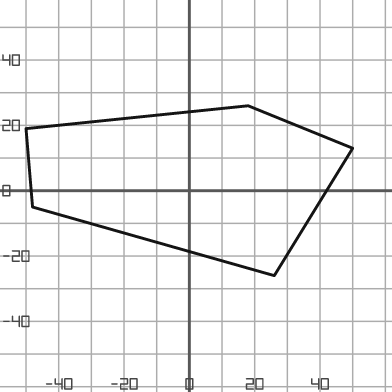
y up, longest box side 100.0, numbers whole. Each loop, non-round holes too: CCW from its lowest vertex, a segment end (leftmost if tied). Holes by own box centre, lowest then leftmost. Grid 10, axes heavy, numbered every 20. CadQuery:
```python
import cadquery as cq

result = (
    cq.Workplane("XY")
    .moveTo(26.0, -26.0)
    .lineTo(50.0, 13.0)
    .lineTo(18.0, 26.0)
    .lineTo(-50.0, 19.0)
    .lineTo(-48.0, -5.0)
    .close()
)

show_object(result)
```